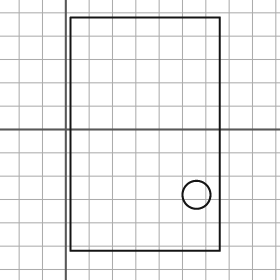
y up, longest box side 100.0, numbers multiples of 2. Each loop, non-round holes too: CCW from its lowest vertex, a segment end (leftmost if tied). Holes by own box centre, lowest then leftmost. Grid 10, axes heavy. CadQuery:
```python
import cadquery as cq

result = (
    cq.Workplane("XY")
    .moveTo(2.0, -52.0)
    .lineTo(66.0, -52.0)
    .lineTo(66.0, 48.0)
    .lineTo(2.0, 48.0)
    .close()
    .moveTo(56.0, -28.0)
    .circle(6.0)
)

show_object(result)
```